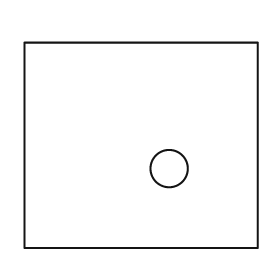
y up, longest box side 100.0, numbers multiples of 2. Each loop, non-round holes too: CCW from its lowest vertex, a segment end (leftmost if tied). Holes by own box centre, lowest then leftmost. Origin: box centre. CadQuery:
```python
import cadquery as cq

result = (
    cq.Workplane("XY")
    .moveTo(-50.0, -44.0)
    .lineTo(50.0, -44.0)
    .lineTo(50.0, 44.0)
    .lineTo(-50.0, 44.0)
    .close()
    .moveTo(12.0, -10.0)
    .circle(8.0)
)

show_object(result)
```